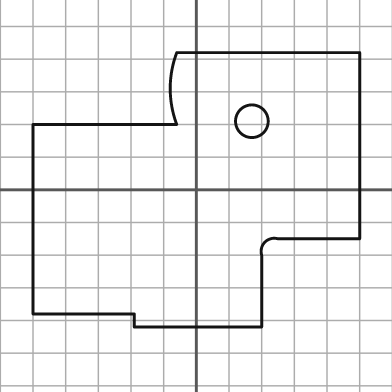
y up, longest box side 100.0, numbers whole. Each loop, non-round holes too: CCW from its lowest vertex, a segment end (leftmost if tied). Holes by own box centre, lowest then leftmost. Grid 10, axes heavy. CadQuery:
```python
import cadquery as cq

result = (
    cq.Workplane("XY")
    .moveTo(-19.0, -42.0)
    .lineTo(20.0, -42.0)
    .lineTo(20.0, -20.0)
    .threePointArc((21.0, -16.0), (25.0, -15.0))
    .lineTo(50.0, -15.0)
    .lineTo(50.0, 42.0)
    .lineTo(-6.0, 42.0)
    .threePointArc((-8.0, 31.0), (-6.0, 20.0))
    .lineTo(-50.0, 20.0)
    .lineTo(-50.0, -38.0)
    .lineTo(-19.0, -38.0)
    .close()
    .moveTo(17.0, 21.0)
    .circle(5.0)
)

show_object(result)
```